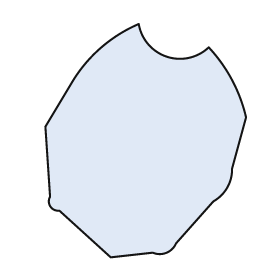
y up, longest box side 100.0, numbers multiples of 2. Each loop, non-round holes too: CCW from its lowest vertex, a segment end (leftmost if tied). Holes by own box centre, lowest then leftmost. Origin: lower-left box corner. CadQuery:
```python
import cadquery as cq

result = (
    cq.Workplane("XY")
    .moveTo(28.0, 0.0)
    .lineTo(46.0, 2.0)
    .threePointArc((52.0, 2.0), (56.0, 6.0))
    .lineTo(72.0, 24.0)
    .threePointArc((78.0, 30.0), (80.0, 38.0))
    .lineTo(86.0, 60.0)
    .threePointArc((80.0, 76.0), (70.0, 90.0))
    .threePointArc((52.0, 86.0), (40.0, 100.0))
    .threePointArc((24.0, 90.0), (12.0, 76.0))
    .lineTo(0.0, 56.0)
    .lineTo(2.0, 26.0)
    .threePointArc((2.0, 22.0), (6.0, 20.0))
    .close()
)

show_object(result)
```